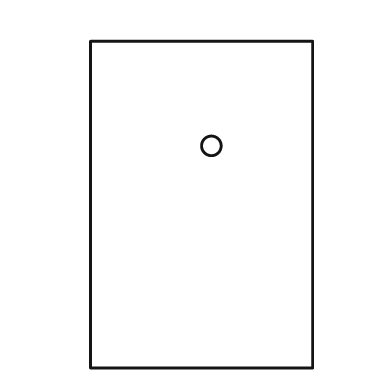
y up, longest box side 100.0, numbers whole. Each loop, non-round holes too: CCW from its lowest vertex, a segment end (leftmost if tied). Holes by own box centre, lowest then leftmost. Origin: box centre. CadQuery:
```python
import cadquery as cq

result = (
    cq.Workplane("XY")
    .moveTo(-34.0, -50.0)
    .lineTo(34.0, -50.0)
    .lineTo(34.0, 50.0)
    .lineTo(-34.0, 50.0)
    .close()
    .moveTo(3.0, 18.0)
    .circle(3.0)
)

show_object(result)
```